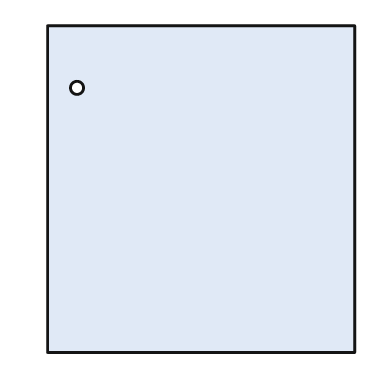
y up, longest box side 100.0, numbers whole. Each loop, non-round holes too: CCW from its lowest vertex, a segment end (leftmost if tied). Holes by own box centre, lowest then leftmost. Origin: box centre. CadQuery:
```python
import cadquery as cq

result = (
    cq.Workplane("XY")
    .moveTo(-47.0, -50.0)
    .lineTo(47.0, -50.0)
    .lineTo(47.0, 50.0)
    .lineTo(-47.0, 50.0)
    .close()
    .moveTo(-38.0, 31.0)
    .circle(2.0)
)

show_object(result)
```